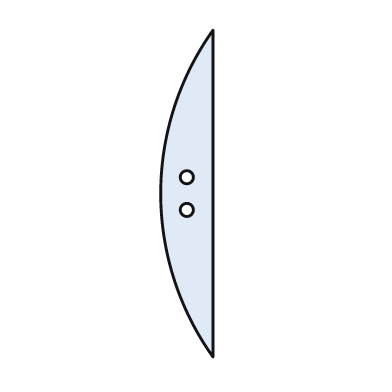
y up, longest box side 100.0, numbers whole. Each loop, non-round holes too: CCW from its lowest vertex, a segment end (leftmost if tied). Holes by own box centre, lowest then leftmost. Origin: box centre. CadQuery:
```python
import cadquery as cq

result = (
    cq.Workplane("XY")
    .moveTo(8.0, -50.0)
    .lineTo(8.0, 50.0)
    .threePointArc((-8.0, 0.0), (8.0, -50.0))
    .close()
    .moveTo(0.0, -5.0)
    .circle(2.0)
    .moveTo(0.0, 5.0)
    .circle(2.0)
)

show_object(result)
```